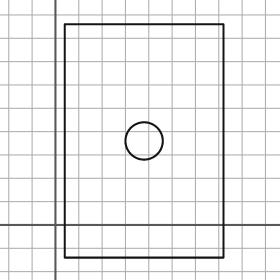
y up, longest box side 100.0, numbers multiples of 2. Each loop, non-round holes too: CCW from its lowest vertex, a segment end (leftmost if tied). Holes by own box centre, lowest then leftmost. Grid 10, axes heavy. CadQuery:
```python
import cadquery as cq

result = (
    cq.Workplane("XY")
    .moveTo(4.0, -14.0)
    .lineTo(72.0, -14.0)
    .lineTo(72.0, 86.0)
    .lineTo(4.0, 86.0)
    .close()
    .moveTo(38.0, 36.0)
    .circle(8.0)
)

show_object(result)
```